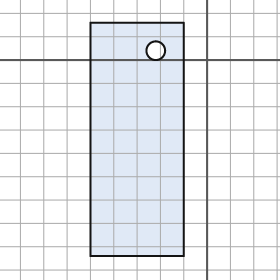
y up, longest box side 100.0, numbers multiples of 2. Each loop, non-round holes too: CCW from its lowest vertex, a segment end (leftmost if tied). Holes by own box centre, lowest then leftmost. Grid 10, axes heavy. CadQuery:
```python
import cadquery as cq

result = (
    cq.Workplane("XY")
    .moveTo(-50.0, -84.0)
    .lineTo(-10.0, -84.0)
    .lineTo(-10.0, 16.0)
    .lineTo(-50.0, 16.0)
    .close()
    .moveTo(-22.0, 4.0)
    .circle(4.0)
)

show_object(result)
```